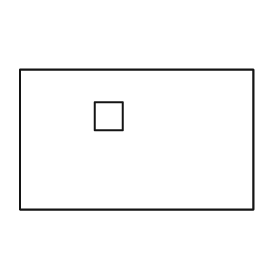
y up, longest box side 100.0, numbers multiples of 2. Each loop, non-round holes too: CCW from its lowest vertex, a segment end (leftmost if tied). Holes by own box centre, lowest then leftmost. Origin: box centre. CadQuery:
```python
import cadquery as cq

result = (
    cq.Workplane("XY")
    .moveTo(-50.0, -30.0)
    .lineTo(50.0, -30.0)
    .lineTo(50.0, 30.0)
    .lineTo(-50.0, 30.0)
    .close()
    .moveTo(-18.0, 4.0)
    .lineTo(-6.0, 4.0)
    .lineTo(-6.0, 16.0)
    .lineTo(-18.0, 16.0)
    .close()
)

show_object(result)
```